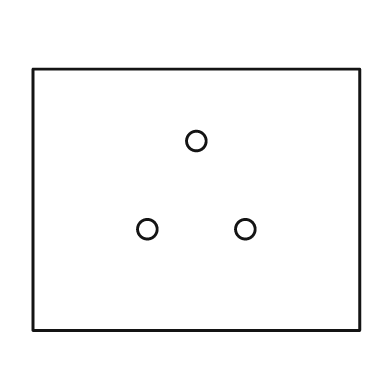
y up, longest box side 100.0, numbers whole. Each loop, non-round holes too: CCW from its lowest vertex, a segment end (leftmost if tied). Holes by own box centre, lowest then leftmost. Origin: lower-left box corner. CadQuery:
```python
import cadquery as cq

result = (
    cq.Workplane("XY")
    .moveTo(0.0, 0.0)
    .lineTo(100.0, 0.0)
    .lineTo(100.0, 80.0)
    .lineTo(0.0, 80.0)
    .close()
    .moveTo(35.0, 31.0)
    .circle(3.0)
    .moveTo(65.0, 31.0)
    .circle(3.0)
    .moveTo(50.0, 58.0)
    .circle(3.0)
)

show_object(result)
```